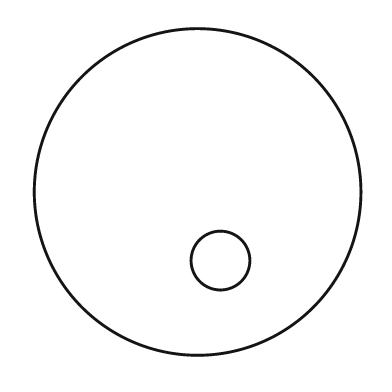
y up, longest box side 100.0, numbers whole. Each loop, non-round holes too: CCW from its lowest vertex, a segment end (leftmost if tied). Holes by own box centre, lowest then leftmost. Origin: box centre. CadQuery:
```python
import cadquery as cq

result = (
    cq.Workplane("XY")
    .moveTo(0.0, 0.0)
    .circle(50.0)
    .moveTo(7.0, -21.0)
    .circle(9.0)
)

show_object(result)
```